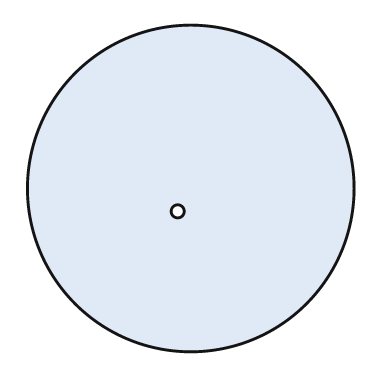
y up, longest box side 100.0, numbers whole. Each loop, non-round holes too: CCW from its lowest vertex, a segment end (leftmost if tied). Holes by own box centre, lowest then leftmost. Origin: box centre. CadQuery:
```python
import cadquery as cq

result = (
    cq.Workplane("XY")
    .moveTo(0.0, 0.0)
    .circle(50.0)
    .moveTo(-4.0, -7.0)
    .circle(2.0)
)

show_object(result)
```